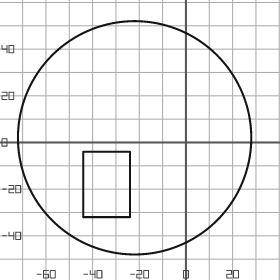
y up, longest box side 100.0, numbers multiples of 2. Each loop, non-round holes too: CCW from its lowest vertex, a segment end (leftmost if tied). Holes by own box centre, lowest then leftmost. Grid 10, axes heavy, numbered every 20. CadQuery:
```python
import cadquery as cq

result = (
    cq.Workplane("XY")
    .moveTo(-22.0, 2.0)
    .circle(50.0)
    .moveTo(-44.0, -32.0)
    .lineTo(-24.0, -32.0)
    .lineTo(-24.0, -4.0)
    .lineTo(-44.0, -4.0)
    .close()
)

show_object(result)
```